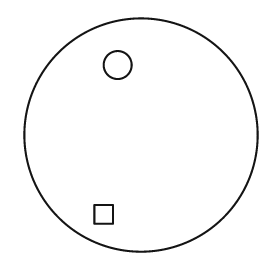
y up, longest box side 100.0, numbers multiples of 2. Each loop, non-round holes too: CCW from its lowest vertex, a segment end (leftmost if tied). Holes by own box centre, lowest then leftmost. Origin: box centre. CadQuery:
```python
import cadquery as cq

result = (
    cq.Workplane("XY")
    .moveTo(0.0, 0.0)
    .circle(50.0)
    .moveTo(-20.0, -38.0)
    .lineTo(-12.0, -38.0)
    .lineTo(-12.0, -30.0)
    .lineTo(-20.0, -30.0)
    .close()
    .moveTo(-10.0, 30.0)
    .circle(6.0)
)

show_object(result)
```